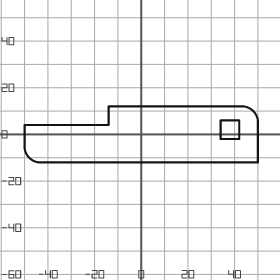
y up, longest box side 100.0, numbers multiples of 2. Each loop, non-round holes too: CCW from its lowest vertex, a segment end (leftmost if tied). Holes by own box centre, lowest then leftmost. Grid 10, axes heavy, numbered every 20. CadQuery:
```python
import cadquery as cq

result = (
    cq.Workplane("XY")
    .moveTo(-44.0, -12.0)
    .lineTo(50.0, -12.0)
    .lineTo(50.0, 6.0)
    .threePointArc((48.0, 10.0), (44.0, 12.0))
    .lineTo(-14.0, 12.0)
    .lineTo(-14.0, 4.0)
    .lineTo(-50.0, 4.0)
    .lineTo(-50.0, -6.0)
    .threePointArc((-48.0, -10.0), (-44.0, -12.0))
    .close()
    .moveTo(34.0, -2.0)
    .lineTo(42.0, -2.0)
    .lineTo(42.0, 6.0)
    .lineTo(34.0, 6.0)
    .close()
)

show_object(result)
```